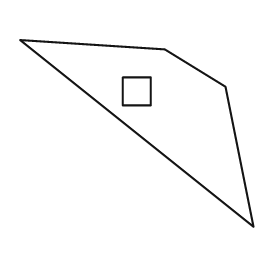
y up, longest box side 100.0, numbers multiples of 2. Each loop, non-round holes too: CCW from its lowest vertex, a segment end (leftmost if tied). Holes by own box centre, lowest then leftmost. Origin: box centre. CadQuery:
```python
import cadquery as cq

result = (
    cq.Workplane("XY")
    .moveTo(50.0, -40.0)
    .lineTo(38.0, 20.0)
    .lineTo(12.0, 36.0)
    .lineTo(-50.0, 40.0)
    .close()
    .moveTo(-6.0, 12.0)
    .lineTo(6.0, 12.0)
    .lineTo(6.0, 24.0)
    .lineTo(-6.0, 24.0)
    .close()
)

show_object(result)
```